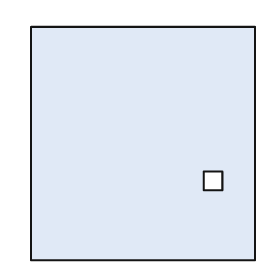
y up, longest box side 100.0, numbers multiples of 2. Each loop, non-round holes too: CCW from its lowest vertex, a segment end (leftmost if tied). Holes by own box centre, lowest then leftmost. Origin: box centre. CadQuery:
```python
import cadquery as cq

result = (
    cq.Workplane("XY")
    .moveTo(-48.0, -50.0)
    .lineTo(48.0, -50.0)
    .lineTo(48.0, 50.0)
    .lineTo(-48.0, 50.0)
    .close()
    .moveTo(26.0, -20.0)
    .lineTo(34.0, -20.0)
    .lineTo(34.0, -12.0)
    .lineTo(26.0, -12.0)
    .close()
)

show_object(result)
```